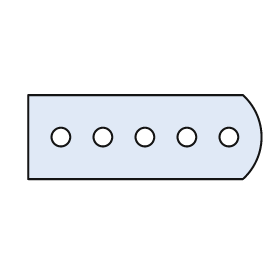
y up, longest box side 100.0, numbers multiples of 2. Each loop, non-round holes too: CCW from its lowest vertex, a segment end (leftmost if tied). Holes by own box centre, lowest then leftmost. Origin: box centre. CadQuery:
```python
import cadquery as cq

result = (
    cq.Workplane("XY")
    .moveTo(-50.0, -18.0)
    .lineTo(42.0, -18.0)
    .threePointArc((50.0, 0.0), (42.0, 18.0))
    .lineTo(-50.0, 18.0)
    .close()
    .moveTo(-36.0, 0.0)
    .circle(4.0)
    .moveTo(-18.0, 0.0)
    .circle(4.0)
    .moveTo(0.0, 0.0)
    .circle(4.0)
    .moveTo(18.0, 0.0)
    .circle(4.0)
    .moveTo(36.0, 0.0)
    .circle(4.0)
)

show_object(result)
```